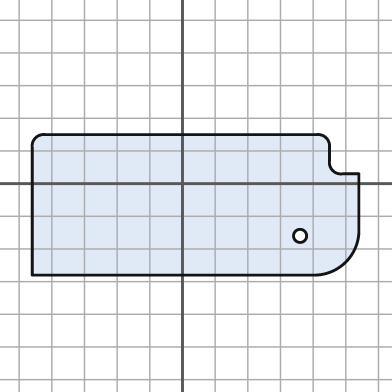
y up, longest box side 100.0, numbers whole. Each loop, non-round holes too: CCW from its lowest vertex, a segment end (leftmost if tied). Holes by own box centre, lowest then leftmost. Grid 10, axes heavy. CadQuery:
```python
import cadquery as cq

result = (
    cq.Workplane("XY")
    .moveTo(-46.0, -28.0)
    .lineTo(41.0, -28.0)
    .threePointArc((50.0, -24.0), (54.0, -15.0))
    .lineTo(54.0, 3.0)
    .lineTo(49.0, 3.0)
    .threePointArc((46.0, 4.0), (45.0, 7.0))
    .lineTo(45.0, 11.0)
    .threePointArc((44.0, 14.0), (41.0, 15.0))
    .lineTo(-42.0, 15.0)
    .threePointArc((-45.0, 14.0), (-46.0, 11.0))
    .close()
    .moveTo(36.0, -16.0)
    .circle(2.0)
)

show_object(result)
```